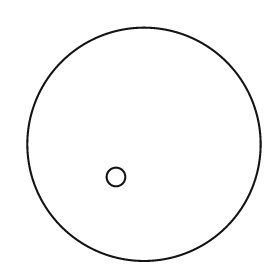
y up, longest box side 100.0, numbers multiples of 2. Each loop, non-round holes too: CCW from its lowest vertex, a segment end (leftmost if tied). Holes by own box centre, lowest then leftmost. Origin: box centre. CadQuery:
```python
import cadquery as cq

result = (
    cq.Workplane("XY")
    .moveTo(0.0, 0.0)
    .circle(50.0)
    .moveTo(-12.0, -14.0)
    .circle(4.0)
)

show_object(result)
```